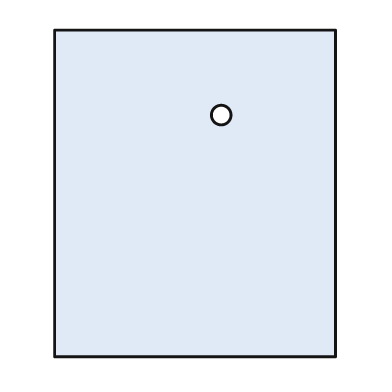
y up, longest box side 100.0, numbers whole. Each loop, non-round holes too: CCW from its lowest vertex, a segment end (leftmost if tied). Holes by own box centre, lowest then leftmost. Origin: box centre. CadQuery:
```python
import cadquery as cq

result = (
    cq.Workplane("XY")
    .moveTo(-43.0, -50.0)
    .lineTo(43.0, -50.0)
    .lineTo(43.0, 50.0)
    .lineTo(-43.0, 50.0)
    .close()
    .moveTo(8.0, 24.0)
    .circle(3.0)
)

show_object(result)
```